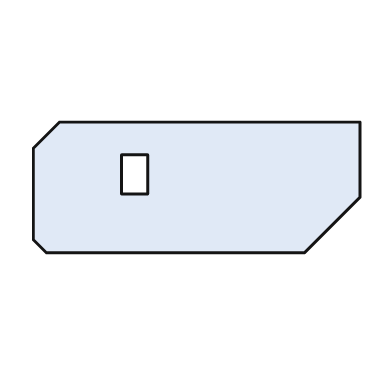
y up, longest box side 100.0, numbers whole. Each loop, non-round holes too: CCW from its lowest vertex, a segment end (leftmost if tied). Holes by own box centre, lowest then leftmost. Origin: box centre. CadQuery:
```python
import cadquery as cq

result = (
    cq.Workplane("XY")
    .moveTo(-46.0, -20.0)
    .lineTo(33.0, -20.0)
    .lineTo(50.0, -3.0)
    .lineTo(50.0, 20.0)
    .lineTo(-42.0, 20.0)
    .lineTo(-50.0, 12.0)
    .lineTo(-50.0, -16.0)
    .close()
    .moveTo(-23.0, -2.0)
    .lineTo(-15.0, -2.0)
    .lineTo(-15.0, 10.0)
    .lineTo(-23.0, 10.0)
    .close()
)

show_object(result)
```